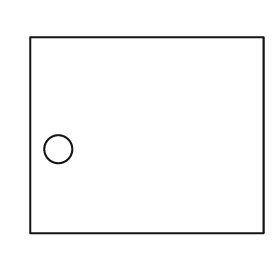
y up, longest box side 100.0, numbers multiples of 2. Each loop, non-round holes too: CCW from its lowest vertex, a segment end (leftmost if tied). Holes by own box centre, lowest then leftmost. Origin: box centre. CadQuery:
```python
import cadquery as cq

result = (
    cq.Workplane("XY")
    .moveTo(-50.0, -42.0)
    .lineTo(50.0, -42.0)
    .lineTo(50.0, 42.0)
    .lineTo(-50.0, 42.0)
    .close()
    .moveTo(-38.0, -6.0)
    .circle(6.0)
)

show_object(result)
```